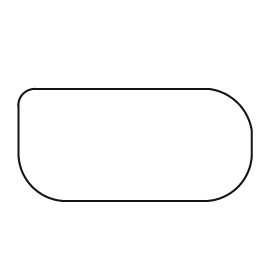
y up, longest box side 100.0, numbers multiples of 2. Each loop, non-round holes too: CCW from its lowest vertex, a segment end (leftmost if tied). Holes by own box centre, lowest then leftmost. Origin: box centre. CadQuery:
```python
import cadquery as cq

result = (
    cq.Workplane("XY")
    .moveTo(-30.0, -24.0)
    .lineTo(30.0, -24.0)
    .threePointArc((44.0, -18.0), (50.0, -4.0))
    .lineTo(50.0, 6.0)
    .threePointArc((44.0, 18.0), (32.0, 24.0))
    .lineTo(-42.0, 24.0)
    .threePointArc((-48.0, 22.0), (-50.0, 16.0))
    .lineTo(-50.0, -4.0)
    .threePointArc((-44.0, -18.0), (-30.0, -24.0))
    .close()
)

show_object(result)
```